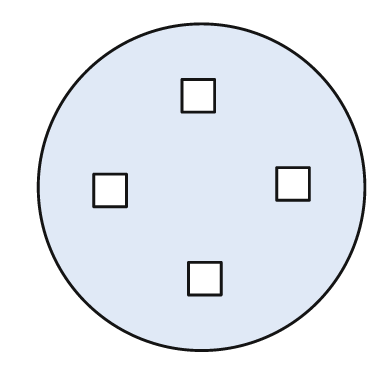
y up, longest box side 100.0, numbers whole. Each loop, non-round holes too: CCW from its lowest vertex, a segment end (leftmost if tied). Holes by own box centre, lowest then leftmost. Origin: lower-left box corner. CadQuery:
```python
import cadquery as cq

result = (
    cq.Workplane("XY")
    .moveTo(50.0, 50.0)
    .circle(50.0)
    .moveTo(46.0, 17.0)
    .lineTo(56.0, 17.0)
    .lineTo(56.0, 27.0)
    .lineTo(46.0, 27.0)
    .close()
    .moveTo(17.0, 44.0)
    .lineTo(27.0, 44.0)
    .lineTo(27.0, 54.0)
    .lineTo(17.0, 54.0)
    .close()
    .moveTo(73.0, 46.0)
    .lineTo(83.0, 46.0)
    .lineTo(83.0, 56.0)
    .lineTo(73.0, 56.0)
    .close()
    .moveTo(44.0, 73.0)
    .lineTo(54.0, 73.0)
    .lineTo(54.0, 83.0)
    .lineTo(44.0, 83.0)
    .close()
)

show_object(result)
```